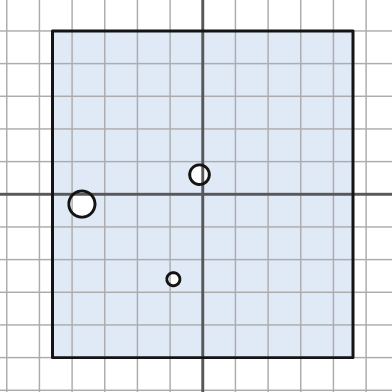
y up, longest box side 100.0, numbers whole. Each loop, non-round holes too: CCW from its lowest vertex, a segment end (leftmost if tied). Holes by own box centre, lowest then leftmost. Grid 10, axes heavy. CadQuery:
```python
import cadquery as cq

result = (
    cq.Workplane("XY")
    .moveTo(-46.0, -50.0)
    .lineTo(46.0, -50.0)
    .lineTo(46.0, 50.0)
    .lineTo(-46.0, 50.0)
    .close()
    .moveTo(-9.0, -26.0)
    .circle(2.0)
    .moveTo(-37.0, -3.0)
    .circle(4.0)
    .moveTo(-1.0, 6.0)
    .circle(3.0)
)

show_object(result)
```